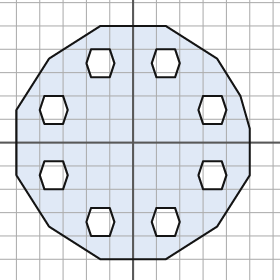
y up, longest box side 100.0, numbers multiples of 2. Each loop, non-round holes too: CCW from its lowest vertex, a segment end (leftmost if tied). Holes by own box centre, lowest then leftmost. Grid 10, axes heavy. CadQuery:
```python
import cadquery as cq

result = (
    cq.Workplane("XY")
    .moveTo(-14.0, -50.0)
    .lineTo(14.0, -50.0)
    .lineTo(36.0, -36.0)
    .lineTo(50.0, -14.0)
    .lineTo(50.0, 6.0)
    .lineTo(46.0, 20.0)
    .lineTo(36.0, 36.0)
    .lineTo(14.0, 50.0)
    .lineTo(-14.0, 50.0)
    .lineTo(-36.0, 36.0)
    .lineTo(-50.0, 14.0)
    .lineTo(-50.0, -14.0)
    .lineTo(-36.0, -36.0)
    .close()
    .moveTo(-18.0, -40.0)
    .lineTo(-10.0, -40.0)
    .lineTo(-8.0, -34.0)
    .lineTo(-10.0, -28.0)
    .lineTo(-18.0, -28.0)
    .lineTo(-20.0, -34.0)
    .close()
    .moveTo(10.0, -40.0)
    .lineTo(18.0, -40.0)
    .lineTo(20.0, -34.0)
    .lineTo(18.0, -28.0)
    .lineTo(10.0, -28.0)
    .lineTo(8.0, -34.0)
    .close()
    .moveTo(-38.0, -20.0)
    .lineTo(-30.0, -20.0)
    .lineTo(-28.0, -14.0)
    .lineTo(-30.0, -8.0)
    .lineTo(-38.0, -8.0)
    .lineTo(-40.0, -14.0)
    .close()
    .moveTo(30.0, -20.0)
    .lineTo(38.0, -20.0)
    .lineTo(40.0, -14.0)
    .lineTo(38.0, -8.0)
    .lineTo(30.0, -8.0)
    .lineTo(28.0, -14.0)
    .close()
    .moveTo(-38.0, 8.0)
    .lineTo(-30.0, 8.0)
    .lineTo(-28.0, 14.0)
    .lineTo(-30.0, 20.0)
    .lineTo(-38.0, 20.0)
    .lineTo(-40.0, 14.0)
    .close()
    .moveTo(30.0, 8.0)
    .lineTo(38.0, 8.0)
    .lineTo(40.0, 14.0)
    .lineTo(38.0, 20.0)
    .lineTo(30.0, 20.0)
    .lineTo(28.0, 14.0)
    .close()
    .moveTo(-18.0, 28.0)
    .lineTo(-10.0, 28.0)
    .lineTo(-8.0, 34.0)
    .lineTo(-10.0, 40.0)
    .lineTo(-18.0, 40.0)
    .lineTo(-20.0, 34.0)
    .close()
    .moveTo(10.0, 28.0)
    .lineTo(18.0, 28.0)
    .lineTo(20.0, 34.0)
    .lineTo(18.0, 40.0)
    .lineTo(10.0, 40.0)
    .lineTo(8.0, 34.0)
    .close()
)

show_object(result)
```